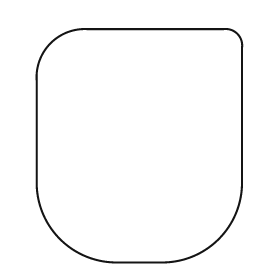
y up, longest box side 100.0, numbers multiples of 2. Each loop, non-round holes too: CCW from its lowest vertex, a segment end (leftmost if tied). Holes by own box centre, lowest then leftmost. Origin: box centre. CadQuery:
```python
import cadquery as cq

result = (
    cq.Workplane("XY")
    .moveTo(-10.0, -50.0)
    .lineTo(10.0, -50.0)
    .threePointArc((34.0, -40.0), (44.0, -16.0))
    .lineTo(44.0, 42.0)
    .threePointArc((42.0, 48.0), (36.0, 50.0))
    .lineTo(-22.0, 50.0)
    .threePointArc((-38.0, 44.0), (-44.0, 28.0))
    .lineTo(-44.0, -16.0)
    .threePointArc((-34.0, -40.0), (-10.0, -50.0))
    .close()
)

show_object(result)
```